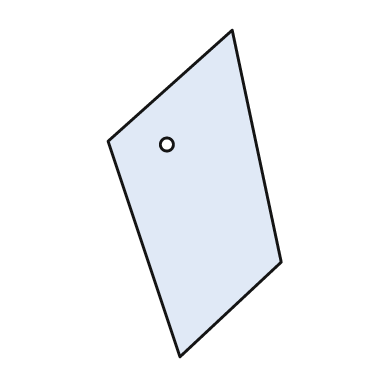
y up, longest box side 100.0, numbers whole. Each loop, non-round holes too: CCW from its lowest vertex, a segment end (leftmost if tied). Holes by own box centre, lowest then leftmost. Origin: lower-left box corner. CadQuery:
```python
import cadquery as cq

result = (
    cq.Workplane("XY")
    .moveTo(22.0, 0.0)
    .lineTo(53.0, 29.0)
    .lineTo(38.0, 100.0)
    .lineTo(0.0, 66.0)
    .close()
    .moveTo(18.0, 65.0)
    .circle(2.0)
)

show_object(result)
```